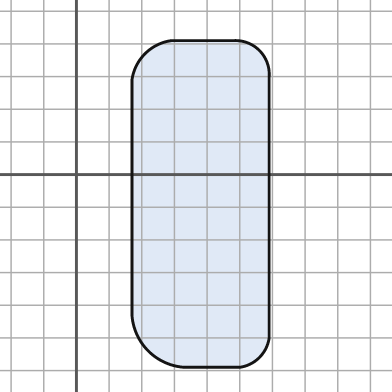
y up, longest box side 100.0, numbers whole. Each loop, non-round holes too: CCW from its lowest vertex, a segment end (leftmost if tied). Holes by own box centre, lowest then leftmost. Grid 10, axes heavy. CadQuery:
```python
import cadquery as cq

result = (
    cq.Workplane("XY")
    .moveTo(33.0, -59.0)
    .lineTo(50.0, -59.0)
    .threePointArc((56.0, -56.0), (59.0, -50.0))
    .lineTo(59.0, 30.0)
    .threePointArc((56.0, 38.0), (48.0, 41.0))
    .lineTo(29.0, 41.0)
    .threePointArc((21.0, 37.0), (17.0, 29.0))
    .lineTo(17.0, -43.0)
    .threePointArc((22.0, -54.0), (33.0, -59.0))
    .close()
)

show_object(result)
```